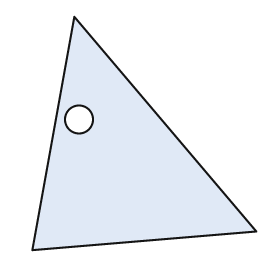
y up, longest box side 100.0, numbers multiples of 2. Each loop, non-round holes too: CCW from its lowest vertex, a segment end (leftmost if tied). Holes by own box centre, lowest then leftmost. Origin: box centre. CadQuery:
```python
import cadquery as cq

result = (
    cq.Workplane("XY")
    .moveTo(-48.0, -50.0)
    .lineTo(48.0, -42.0)
    .lineTo(-30.0, 50.0)
    .close()
    .moveTo(-28.0, 6.0)
    .circle(6.0)
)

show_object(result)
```